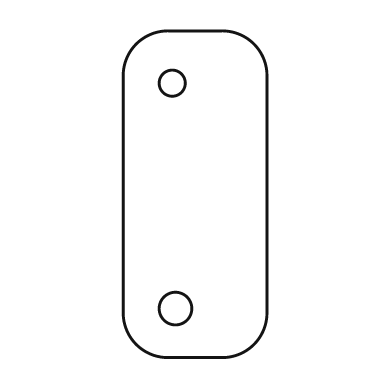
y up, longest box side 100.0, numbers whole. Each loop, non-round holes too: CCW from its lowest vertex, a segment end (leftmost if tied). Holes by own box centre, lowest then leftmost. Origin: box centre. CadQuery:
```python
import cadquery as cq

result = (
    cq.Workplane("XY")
    .moveTo(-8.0, -50.0)
    .lineTo(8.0, -50.0)
    .threePointArc((18.0, -46.0), (22.0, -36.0))
    .lineTo(22.0, 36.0)
    .threePointArc((18.0, 46.0), (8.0, 50.0))
    .lineTo(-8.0, 50.0)
    .threePointArc((-18.0, 46.0), (-22.0, 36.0))
    .lineTo(-22.0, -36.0)
    .threePointArc((-18.0, -46.0), (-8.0, -50.0))
    .close()
    .moveTo(-6.0, -35.0)
    .circle(5.0)
    .moveTo(-7.0, 34.0)
    .circle(4.0)
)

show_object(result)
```